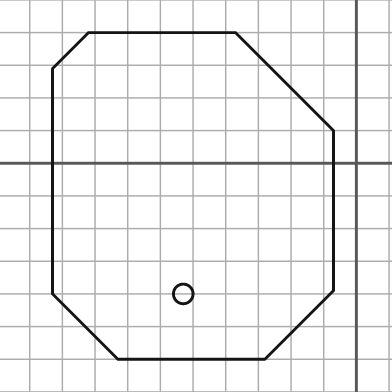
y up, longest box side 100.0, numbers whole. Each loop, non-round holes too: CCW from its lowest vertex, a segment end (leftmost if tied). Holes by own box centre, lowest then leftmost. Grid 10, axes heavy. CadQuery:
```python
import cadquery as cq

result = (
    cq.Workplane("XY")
    .moveTo(-73.0, -60.0)
    .lineTo(-28.0, -60.0)
    .lineTo(-7.0, -39.0)
    .lineTo(-7.0, 10.0)
    .lineTo(-37.0, 40.0)
    .lineTo(-82.0, 40.0)
    .lineTo(-93.0, 29.0)
    .lineTo(-93.0, -40.0)
    .close()
    .moveTo(-53.0, -40.0)
    .circle(3.0)
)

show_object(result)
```